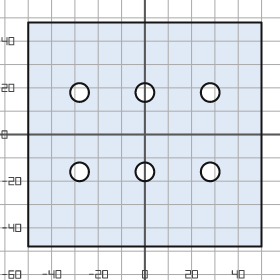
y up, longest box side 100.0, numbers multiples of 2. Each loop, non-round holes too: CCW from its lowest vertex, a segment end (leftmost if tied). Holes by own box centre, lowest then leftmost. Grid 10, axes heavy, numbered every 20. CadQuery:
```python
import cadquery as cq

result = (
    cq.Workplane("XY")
    .moveTo(-50.0, -48.0)
    .lineTo(50.0, -48.0)
    .lineTo(50.0, 48.0)
    .lineTo(-50.0, 48.0)
    .close()
    .moveTo(-28.0, -16.0)
    .circle(4.0)
    .moveTo(0.0, -16.0)
    .circle(4.0)
    .moveTo(28.0, -16.0)
    .circle(4.0)
    .moveTo(-28.0, 18.0)
    .circle(4.0)
    .moveTo(0.0, 18.0)
    .circle(4.0)
    .moveTo(28.0, 18.0)
    .circle(4.0)
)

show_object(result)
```